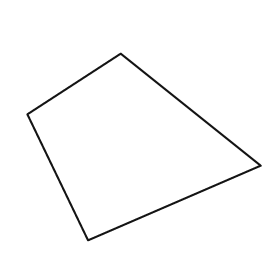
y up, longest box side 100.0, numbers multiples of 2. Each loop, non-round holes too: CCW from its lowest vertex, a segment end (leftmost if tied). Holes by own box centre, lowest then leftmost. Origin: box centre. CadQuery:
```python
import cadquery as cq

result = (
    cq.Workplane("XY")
    .moveTo(-24.0, -40.0)
    .lineTo(50.0, -8.0)
    .lineTo(-10.0, 40.0)
    .lineTo(-50.0, 14.0)
    .close()
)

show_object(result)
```